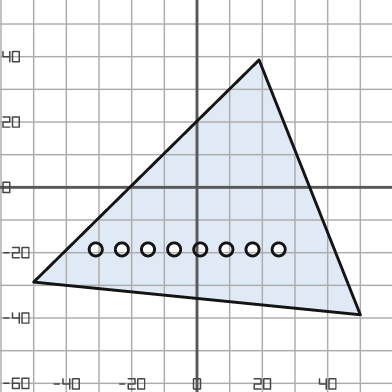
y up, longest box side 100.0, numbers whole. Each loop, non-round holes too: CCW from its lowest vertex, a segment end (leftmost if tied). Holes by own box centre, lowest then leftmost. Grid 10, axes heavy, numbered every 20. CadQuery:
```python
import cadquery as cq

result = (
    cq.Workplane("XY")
    .moveTo(50.0, -39.0)
    .lineTo(19.0, 39.0)
    .lineTo(-50.0, -29.0)
    .close()
    .moveTo(-31.0, -19.0)
    .circle(2.0)
    .moveTo(-23.0, -19.0)
    .circle(2.0)
    .moveTo(-15.0, -19.0)
    .circle(2.0)
    .moveTo(-7.0, -19.0)
    .circle(2.0)
    .moveTo(1.0, -19.0)
    .circle(2.0)
    .moveTo(9.0, -19.0)
    .circle(2.0)
    .moveTo(17.0, -19.0)
    .circle(2.0)
    .moveTo(25.0, -19.0)
    .circle(2.0)
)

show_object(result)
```